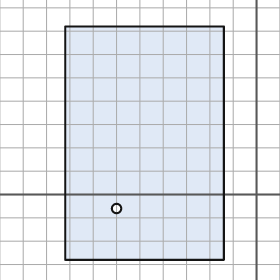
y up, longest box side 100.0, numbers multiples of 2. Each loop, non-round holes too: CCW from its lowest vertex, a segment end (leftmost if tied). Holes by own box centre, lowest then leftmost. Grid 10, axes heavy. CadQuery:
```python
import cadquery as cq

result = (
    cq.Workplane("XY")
    .moveTo(-82.0, -28.0)
    .lineTo(-14.0, -28.0)
    .lineTo(-14.0, 72.0)
    .lineTo(-82.0, 72.0)
    .close()
    .moveTo(-60.0, -6.0)
    .circle(2.0)
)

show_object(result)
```